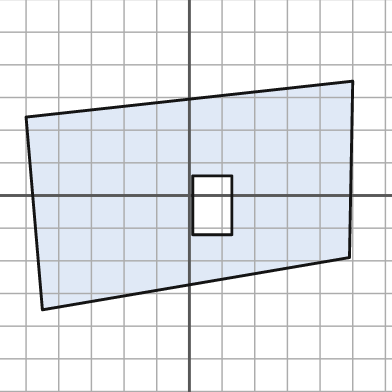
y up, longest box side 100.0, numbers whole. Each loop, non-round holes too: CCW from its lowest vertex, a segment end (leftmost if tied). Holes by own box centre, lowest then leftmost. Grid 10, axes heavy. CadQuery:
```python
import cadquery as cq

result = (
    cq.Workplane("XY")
    .moveTo(-45.0, -35.0)
    .lineTo(49.0, -19.0)
    .lineTo(50.0, 35.0)
    .lineTo(-50.0, 24.0)
    .close()
    .moveTo(1.0, -12.0)
    .lineTo(13.0, -12.0)
    .lineTo(13.0, 6.0)
    .lineTo(1.0, 6.0)
    .close()
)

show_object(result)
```